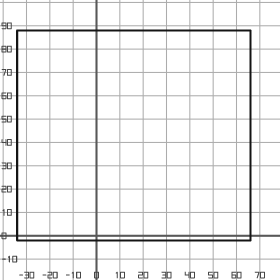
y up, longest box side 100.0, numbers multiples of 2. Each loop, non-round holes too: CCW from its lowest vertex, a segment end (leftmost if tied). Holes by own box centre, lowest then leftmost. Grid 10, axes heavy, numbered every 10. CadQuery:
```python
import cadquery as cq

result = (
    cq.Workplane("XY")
    .moveTo(-34.0, -2.0)
    .lineTo(66.0, -2.0)
    .lineTo(66.0, 88.0)
    .lineTo(-34.0, 88.0)
    .close()
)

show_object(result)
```